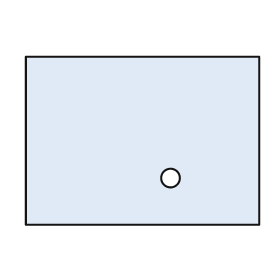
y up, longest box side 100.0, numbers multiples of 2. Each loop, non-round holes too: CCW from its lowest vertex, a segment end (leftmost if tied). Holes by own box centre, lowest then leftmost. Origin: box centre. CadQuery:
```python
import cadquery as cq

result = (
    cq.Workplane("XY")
    .moveTo(-50.0, -36.0)
    .lineTo(50.0, -36.0)
    .lineTo(50.0, 36.0)
    .lineTo(-50.0, 36.0)
    .close()
    .moveTo(12.0, -16.0)
    .circle(4.0)
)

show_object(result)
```